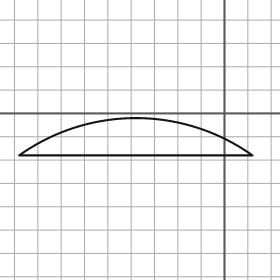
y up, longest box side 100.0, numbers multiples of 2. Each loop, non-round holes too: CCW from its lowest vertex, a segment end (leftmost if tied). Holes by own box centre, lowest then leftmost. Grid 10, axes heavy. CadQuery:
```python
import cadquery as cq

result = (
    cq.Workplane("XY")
    .moveTo(-88.0, -18.0)
    .lineTo(12.0, -18.0)
    .threePointArc((-38.0, -2.0), (-88.0, -18.0))
    .close()
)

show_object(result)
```